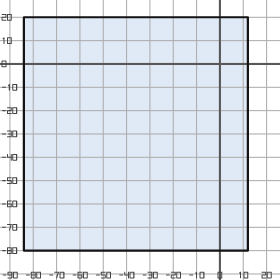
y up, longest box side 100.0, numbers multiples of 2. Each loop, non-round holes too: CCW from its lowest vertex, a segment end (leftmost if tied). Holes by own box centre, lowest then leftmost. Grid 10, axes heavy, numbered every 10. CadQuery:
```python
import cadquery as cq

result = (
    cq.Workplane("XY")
    .moveTo(-84.0, -80.0)
    .lineTo(12.0, -80.0)
    .lineTo(12.0, 20.0)
    .lineTo(-84.0, 20.0)
    .close()
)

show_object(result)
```